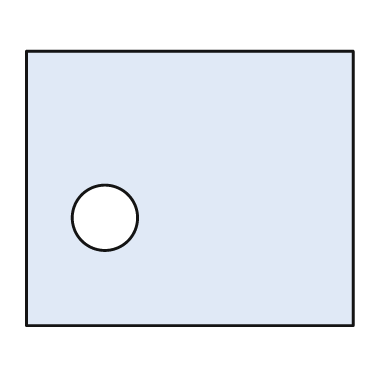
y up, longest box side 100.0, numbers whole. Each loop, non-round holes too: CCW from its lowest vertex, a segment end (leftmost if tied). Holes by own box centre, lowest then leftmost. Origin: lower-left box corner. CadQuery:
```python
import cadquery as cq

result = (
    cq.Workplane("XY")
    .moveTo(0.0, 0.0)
    .lineTo(100.0, 0.0)
    .lineTo(100.0, 84.0)
    .lineTo(0.0, 84.0)
    .close()
    .moveTo(24.0, 33.0)
    .circle(10.0)
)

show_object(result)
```